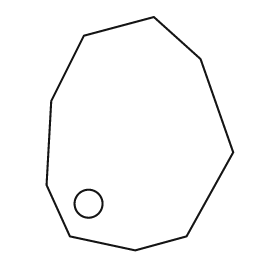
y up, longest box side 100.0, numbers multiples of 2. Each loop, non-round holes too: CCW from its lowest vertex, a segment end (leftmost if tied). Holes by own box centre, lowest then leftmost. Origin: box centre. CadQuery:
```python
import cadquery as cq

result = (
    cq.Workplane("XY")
    .moveTo(-2.0, -50.0)
    .lineTo(20.0, -44.0)
    .lineTo(40.0, -8.0)
    .lineTo(26.0, 32.0)
    .lineTo(6.0, 50.0)
    .lineTo(-24.0, 42.0)
    .lineTo(-38.0, 14.0)
    .lineTo(-40.0, -22.0)
    .lineTo(-30.0, -44.0)
    .close()
    .moveTo(-22.0, -30.0)
    .circle(6.0)
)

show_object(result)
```